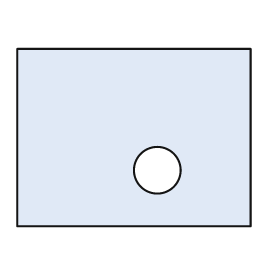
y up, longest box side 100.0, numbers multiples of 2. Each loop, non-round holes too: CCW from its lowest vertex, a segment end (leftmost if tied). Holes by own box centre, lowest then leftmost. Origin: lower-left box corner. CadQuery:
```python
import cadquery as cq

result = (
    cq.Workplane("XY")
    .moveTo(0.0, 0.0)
    .lineTo(100.0, 0.0)
    .lineTo(100.0, 76.0)
    .lineTo(0.0, 76.0)
    .close()
    .moveTo(60.0, 24.0)
    .circle(10.0)
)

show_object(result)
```